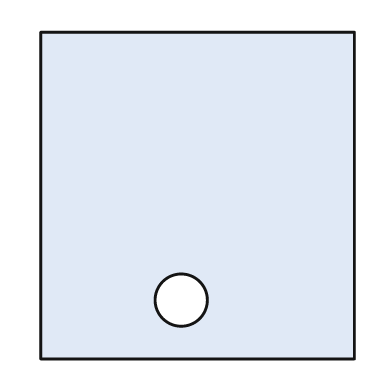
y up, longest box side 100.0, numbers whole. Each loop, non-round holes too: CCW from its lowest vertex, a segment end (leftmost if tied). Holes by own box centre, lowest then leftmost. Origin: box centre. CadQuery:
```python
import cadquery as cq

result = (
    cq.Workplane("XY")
    .moveTo(-48.0, -50.0)
    .lineTo(48.0, -50.0)
    .lineTo(48.0, 50.0)
    .lineTo(-48.0, 50.0)
    .close()
    .moveTo(-5.0, -32.0)
    .circle(8.0)
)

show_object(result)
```